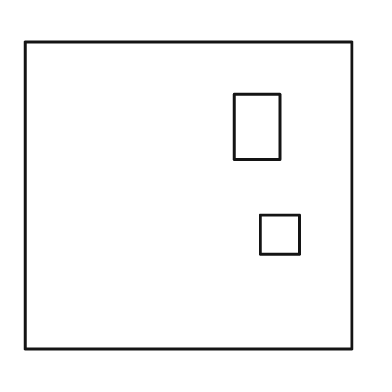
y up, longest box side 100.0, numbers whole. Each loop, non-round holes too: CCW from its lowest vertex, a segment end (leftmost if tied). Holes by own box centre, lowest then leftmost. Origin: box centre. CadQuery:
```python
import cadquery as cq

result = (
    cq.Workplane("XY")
    .moveTo(-50.0, -47.0)
    .lineTo(50.0, -47.0)
    .lineTo(50.0, 47.0)
    .lineTo(-50.0, 47.0)
    .close()
    .moveTo(22.0, -18.0)
    .lineTo(34.0, -18.0)
    .lineTo(34.0, -6.0)
    .lineTo(22.0, -6.0)
    .close()
    .moveTo(14.0, 11.0)
    .lineTo(28.0, 11.0)
    .lineTo(28.0, 31.0)
    .lineTo(14.0, 31.0)
    .close()
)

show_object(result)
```